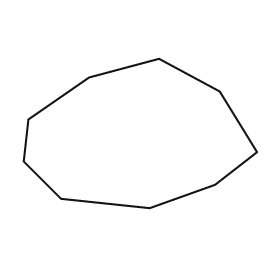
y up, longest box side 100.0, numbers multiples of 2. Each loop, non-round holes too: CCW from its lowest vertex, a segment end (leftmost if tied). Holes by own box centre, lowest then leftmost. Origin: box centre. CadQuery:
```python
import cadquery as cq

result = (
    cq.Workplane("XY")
    .moveTo(4.0, -32.0)
    .lineTo(32.0, -22.0)
    .lineTo(50.0, -8.0)
    .lineTo(34.0, 18.0)
    .lineTo(8.0, 32.0)
    .lineTo(-22.0, 24.0)
    .lineTo(-48.0, 6.0)
    .lineTo(-50.0, -12.0)
    .lineTo(-34.0, -28.0)
    .close()
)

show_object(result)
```